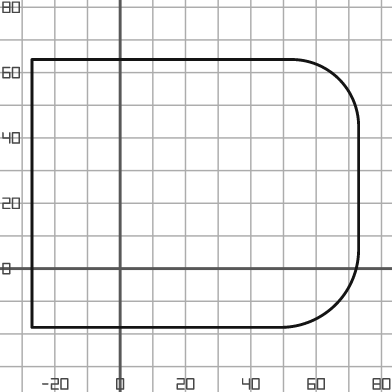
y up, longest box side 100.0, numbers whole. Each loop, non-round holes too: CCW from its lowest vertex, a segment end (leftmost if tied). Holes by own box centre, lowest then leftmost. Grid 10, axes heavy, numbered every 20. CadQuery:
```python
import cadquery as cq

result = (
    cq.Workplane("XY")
    .moveTo(-27.0, -18.0)
    .lineTo(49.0, -18.0)
    .threePointArc((66.0, -11.0), (73.0, 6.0))
    .lineTo(73.0, 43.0)
    .threePointArc((67.0, 58.0), (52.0, 64.0))
    .lineTo(-27.0, 64.0)
    .close()
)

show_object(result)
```